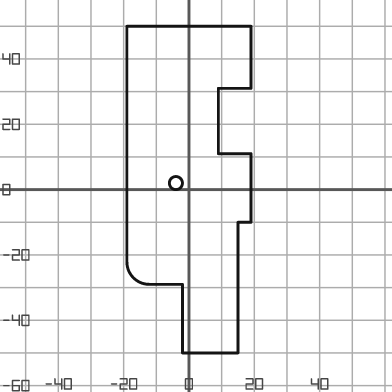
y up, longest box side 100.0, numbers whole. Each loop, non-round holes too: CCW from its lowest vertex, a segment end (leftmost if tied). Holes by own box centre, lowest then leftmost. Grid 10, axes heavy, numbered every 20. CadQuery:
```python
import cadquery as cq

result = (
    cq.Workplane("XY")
    .moveTo(-2.0, -50.0)
    .lineTo(15.0, -50.0)
    .lineTo(15.0, -10.0)
    .lineTo(19.0, -10.0)
    .lineTo(19.0, 11.0)
    .lineTo(9.0, 11.0)
    .lineTo(9.0, 31.0)
    .lineTo(19.0, 31.0)
    .lineTo(19.0, 50.0)
    .lineTo(-19.0, 50.0)
    .lineTo(-19.0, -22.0)
    .threePointArc((-17.0, -27.0), (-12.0, -29.0))
    .lineTo(-2.0, -29.0)
    .close()
    .moveTo(-4.0, 2.0)
    .circle(2.0)
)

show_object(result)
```